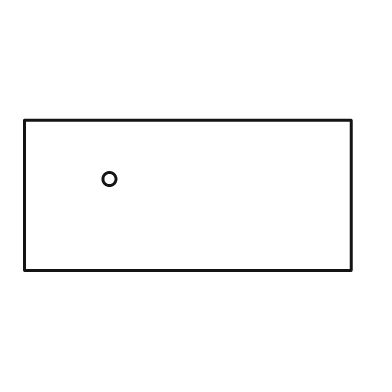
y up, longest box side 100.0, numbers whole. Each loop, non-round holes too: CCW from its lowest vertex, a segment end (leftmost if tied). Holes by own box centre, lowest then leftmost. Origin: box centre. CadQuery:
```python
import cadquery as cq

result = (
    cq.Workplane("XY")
    .moveTo(-50.0, -23.0)
    .lineTo(50.0, -23.0)
    .lineTo(50.0, 23.0)
    .lineTo(-50.0, 23.0)
    .close()
    .moveTo(-24.0, 5.0)
    .circle(2.0)
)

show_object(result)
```